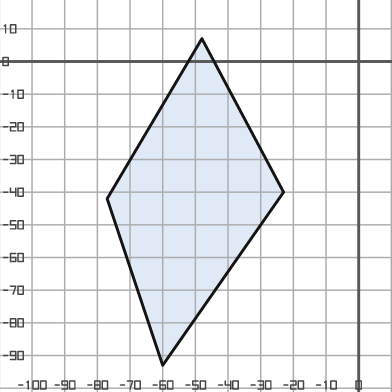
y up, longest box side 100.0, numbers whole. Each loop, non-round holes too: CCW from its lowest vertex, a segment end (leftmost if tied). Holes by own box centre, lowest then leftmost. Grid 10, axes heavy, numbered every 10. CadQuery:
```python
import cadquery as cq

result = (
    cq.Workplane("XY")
    .moveTo(-60.0, -93.0)
    .lineTo(-23.0, -40.0)
    .lineTo(-48.0, 7.0)
    .lineTo(-77.0, -42.0)
    .close()
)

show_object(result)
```